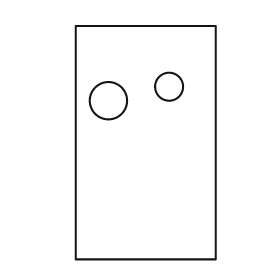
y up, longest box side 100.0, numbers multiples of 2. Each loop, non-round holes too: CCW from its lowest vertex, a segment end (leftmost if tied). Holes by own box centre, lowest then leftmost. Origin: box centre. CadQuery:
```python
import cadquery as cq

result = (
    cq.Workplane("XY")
    .moveTo(-30.0, -50.0)
    .lineTo(30.0, -50.0)
    .lineTo(30.0, 50.0)
    .lineTo(-30.0, 50.0)
    .close()
    .moveTo(-16.0, 18.0)
    .circle(8.0)
    .moveTo(10.0, 24.0)
    .circle(6.0)
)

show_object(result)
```